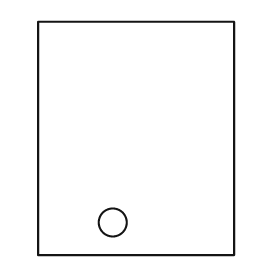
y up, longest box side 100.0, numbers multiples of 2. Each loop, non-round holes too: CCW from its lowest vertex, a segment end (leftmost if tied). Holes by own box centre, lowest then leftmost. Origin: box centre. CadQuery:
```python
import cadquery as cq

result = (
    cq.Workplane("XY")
    .moveTo(-42.0, -50.0)
    .lineTo(42.0, -50.0)
    .lineTo(42.0, 50.0)
    .lineTo(-42.0, 50.0)
    .close()
    .moveTo(-10.0, -36.0)
    .circle(6.0)
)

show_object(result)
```